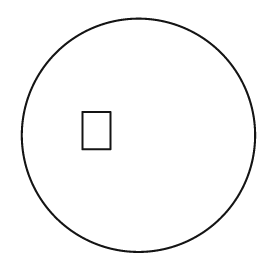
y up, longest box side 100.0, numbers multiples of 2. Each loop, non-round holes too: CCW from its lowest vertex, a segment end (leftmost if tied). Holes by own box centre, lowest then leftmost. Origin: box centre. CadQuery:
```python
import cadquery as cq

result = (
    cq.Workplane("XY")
    .moveTo(0.0, 0.0)
    .circle(50.0)
    .moveTo(-24.0, -6.0)
    .lineTo(-12.0, -6.0)
    .lineTo(-12.0, 10.0)
    .lineTo(-24.0, 10.0)
    .close()
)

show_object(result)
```